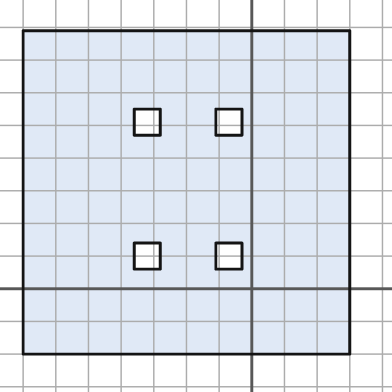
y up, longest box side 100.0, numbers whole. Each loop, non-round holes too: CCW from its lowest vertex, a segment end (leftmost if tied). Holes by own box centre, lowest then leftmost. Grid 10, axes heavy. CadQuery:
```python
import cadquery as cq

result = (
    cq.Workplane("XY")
    .moveTo(-70.0, -20.0)
    .lineTo(30.0, -20.0)
    .lineTo(30.0, 79.0)
    .lineTo(-70.0, 79.0)
    .close()
    .moveTo(-36.0, 6.0)
    .lineTo(-28.0, 6.0)
    .lineTo(-28.0, 14.0)
    .lineTo(-36.0, 14.0)
    .close()
    .moveTo(-11.0, 6.0)
    .lineTo(-3.0, 6.0)
    .lineTo(-3.0, 14.0)
    .lineTo(-11.0, 14.0)
    .close()
    .moveTo(-36.0, 47.0)
    .lineTo(-28.0, 47.0)
    .lineTo(-28.0, 55.0)
    .lineTo(-36.0, 55.0)
    .close()
    .moveTo(-11.0, 47.0)
    .lineTo(-3.0, 47.0)
    .lineTo(-3.0, 55.0)
    .lineTo(-11.0, 55.0)
    .close()
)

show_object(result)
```